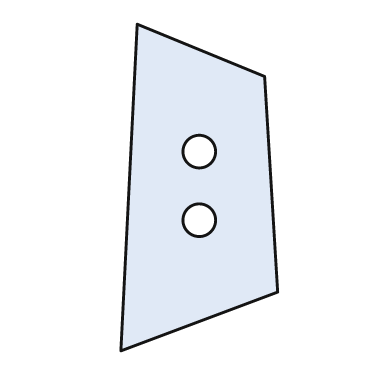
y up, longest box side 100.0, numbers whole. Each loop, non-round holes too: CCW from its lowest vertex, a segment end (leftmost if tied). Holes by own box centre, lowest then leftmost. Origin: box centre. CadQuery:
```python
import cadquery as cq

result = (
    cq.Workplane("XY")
    .moveTo(-24.0, -50.0)
    .lineTo(24.0, -32.0)
    .lineTo(20.0, 34.0)
    .lineTo(-19.0, 50.0)
    .close()
    .moveTo(0.0, -10.0)
    .circle(5.0)
    .moveTo(0.0, 11.0)
    .circle(5.0)
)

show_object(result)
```